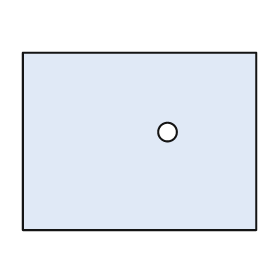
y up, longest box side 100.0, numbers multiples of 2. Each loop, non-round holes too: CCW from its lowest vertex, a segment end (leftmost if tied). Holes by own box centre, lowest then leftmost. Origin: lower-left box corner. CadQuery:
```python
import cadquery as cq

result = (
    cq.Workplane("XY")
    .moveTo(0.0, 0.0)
    .lineTo(100.0, 0.0)
    .lineTo(100.0, 76.0)
    .lineTo(0.0, 76.0)
    .close()
    .moveTo(62.0, 42.0)
    .circle(4.0)
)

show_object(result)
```